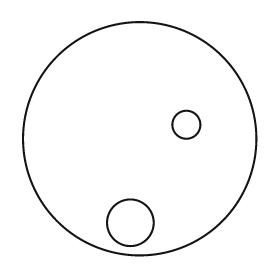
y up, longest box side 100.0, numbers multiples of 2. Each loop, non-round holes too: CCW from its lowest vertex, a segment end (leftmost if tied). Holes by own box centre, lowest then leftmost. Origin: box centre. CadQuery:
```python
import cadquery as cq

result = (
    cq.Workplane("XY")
    .moveTo(0.0, 0.0)
    .circle(50.0)
    .moveTo(-4.0, -36.0)
    .circle(10.0)
    .moveTo(20.0, 6.0)
    .circle(6.0)
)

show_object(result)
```